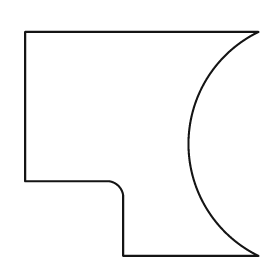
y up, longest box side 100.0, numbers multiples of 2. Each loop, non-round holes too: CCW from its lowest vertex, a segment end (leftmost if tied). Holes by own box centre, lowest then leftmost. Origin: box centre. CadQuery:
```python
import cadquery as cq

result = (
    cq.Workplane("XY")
    .moveTo(-8.0, -48.0)
    .lineTo(50.0, -48.0)
    .threePointArc((20.0, 0.0), (50.0, 48.0))
    .lineTo(-50.0, 48.0)
    .lineTo(-50.0, -16.0)
    .lineTo(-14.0, -16.0)
    .threePointArc((-10.0, -18.0), (-8.0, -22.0))
    .close()
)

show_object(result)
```